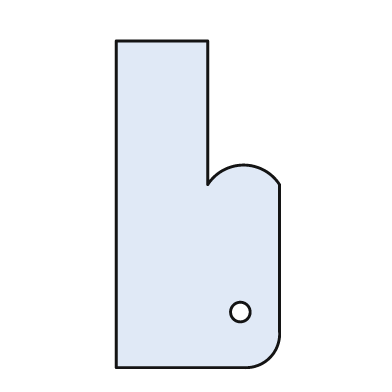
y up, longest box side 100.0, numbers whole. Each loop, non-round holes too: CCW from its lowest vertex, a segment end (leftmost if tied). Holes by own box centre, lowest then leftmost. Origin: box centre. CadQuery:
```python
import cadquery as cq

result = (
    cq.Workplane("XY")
    .moveTo(-25.0, -50.0)
    .lineTo(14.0, -50.0)
    .threePointArc((22.0, -47.0), (25.0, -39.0))
    .lineTo(25.0, 6.0)
    .threePointArc((14.0, 12.0), (3.0, 6.0))
    .lineTo(3.0, 50.0)
    .lineTo(-25.0, 50.0)
    .close()
    .moveTo(13.0, -33.0)
    .circle(3.0)
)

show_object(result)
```